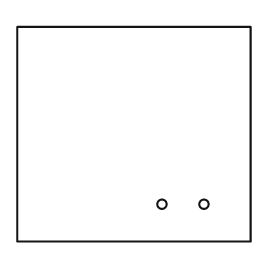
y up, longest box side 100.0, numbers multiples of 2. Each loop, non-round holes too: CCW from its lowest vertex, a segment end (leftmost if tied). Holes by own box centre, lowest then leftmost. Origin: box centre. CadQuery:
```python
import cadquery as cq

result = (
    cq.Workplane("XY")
    .moveTo(-50.0, -46.0)
    .lineTo(50.0, -46.0)
    .lineTo(50.0, 46.0)
    .lineTo(-50.0, 46.0)
    .close()
    .moveTo(12.0, -30.0)
    .circle(2.0)
    .moveTo(30.0, -30.0)
    .circle(2.0)
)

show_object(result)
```